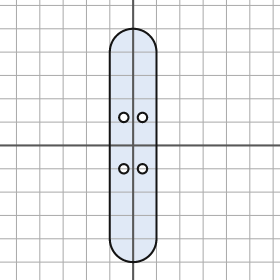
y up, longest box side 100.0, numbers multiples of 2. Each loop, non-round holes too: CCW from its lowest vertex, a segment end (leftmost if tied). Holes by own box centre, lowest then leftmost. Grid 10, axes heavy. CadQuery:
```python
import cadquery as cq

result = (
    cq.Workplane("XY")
    .moveTo(-10.0, -40.0)
    .threePointArc((0.0, -50.0), (10.0, -40.0))
    .lineTo(10.0, 40.0)
    .threePointArc((0.0, 50.0), (-10.0, 40.0))
    .close()
    .moveTo(-4.0, -10.0)
    .circle(2.0)
    .moveTo(4.0, -10.0)
    .circle(2.0)
    .moveTo(-4.0, 12.0)
    .circle(2.0)
    .moveTo(4.0, 12.0)
    .circle(2.0)
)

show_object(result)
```